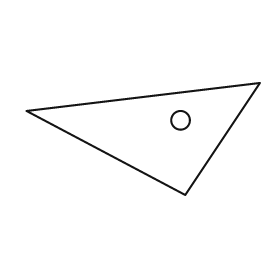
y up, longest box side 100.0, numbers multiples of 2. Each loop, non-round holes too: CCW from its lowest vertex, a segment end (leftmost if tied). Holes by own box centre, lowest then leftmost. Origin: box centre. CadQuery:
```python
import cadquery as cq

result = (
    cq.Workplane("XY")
    .moveTo(18.0, -24.0)
    .lineTo(50.0, 24.0)
    .lineTo(-50.0, 12.0)
    .close()
    .moveTo(16.0, 8.0)
    .circle(4.0)
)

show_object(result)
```